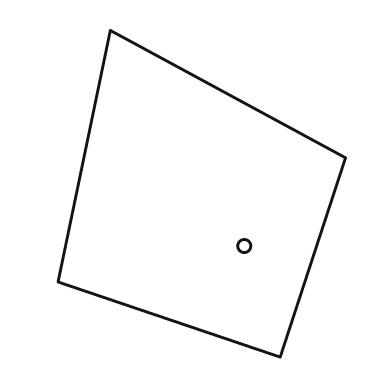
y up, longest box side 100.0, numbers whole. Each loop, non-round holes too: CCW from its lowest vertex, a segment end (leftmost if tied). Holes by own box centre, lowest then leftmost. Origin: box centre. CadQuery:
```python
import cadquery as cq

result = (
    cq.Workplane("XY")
    .moveTo(24.0, -50.0)
    .lineTo(44.0, 11.0)
    .lineTo(-28.0, 50.0)
    .lineTo(-44.0, -27.0)
    .close()
    .moveTo(13.0, -16.0)
    .circle(2.0)
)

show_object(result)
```